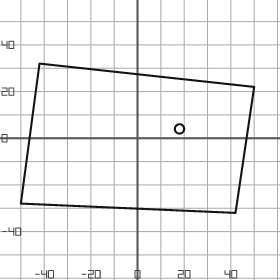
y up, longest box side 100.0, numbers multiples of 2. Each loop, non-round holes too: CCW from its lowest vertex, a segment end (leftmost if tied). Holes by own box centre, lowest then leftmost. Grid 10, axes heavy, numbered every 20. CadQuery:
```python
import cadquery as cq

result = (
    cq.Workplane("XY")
    .moveTo(42.0, -32.0)
    .lineTo(50.0, 22.0)
    .lineTo(-42.0, 32.0)
    .lineTo(-50.0, -28.0)
    .close()
    .moveTo(18.0, 4.0)
    .circle(2.0)
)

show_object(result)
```